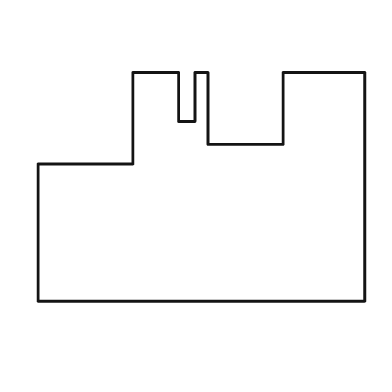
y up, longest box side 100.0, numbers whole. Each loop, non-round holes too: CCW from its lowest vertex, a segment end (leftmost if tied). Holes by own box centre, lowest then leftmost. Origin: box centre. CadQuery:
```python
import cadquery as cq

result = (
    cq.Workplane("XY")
    .moveTo(-50.0, -35.0)
    .lineTo(50.0, -35.0)
    .lineTo(50.0, 35.0)
    .lineTo(25.0, 35.0)
    .lineTo(25.0, 13.0)
    .lineTo(2.0, 13.0)
    .lineTo(2.0, 35.0)
    .lineTo(-2.0, 35.0)
    .lineTo(-2.0, 20.0)
    .lineTo(-7.0, 20.0)
    .lineTo(-7.0, 35.0)
    .lineTo(-21.0, 35.0)
    .lineTo(-21.0, 7.0)
    .lineTo(-50.0, 7.0)
    .close()
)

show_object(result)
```